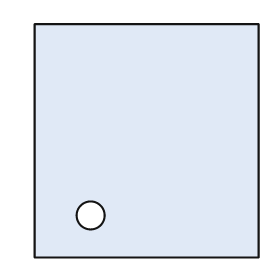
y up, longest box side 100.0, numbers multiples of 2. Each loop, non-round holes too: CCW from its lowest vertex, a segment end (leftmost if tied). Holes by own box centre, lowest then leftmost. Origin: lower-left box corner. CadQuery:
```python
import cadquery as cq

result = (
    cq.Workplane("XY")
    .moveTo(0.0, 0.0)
    .lineTo(96.0, 0.0)
    .lineTo(96.0, 100.0)
    .lineTo(0.0, 100.0)
    .close()
    .moveTo(24.0, 18.0)
    .circle(6.0)
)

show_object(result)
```